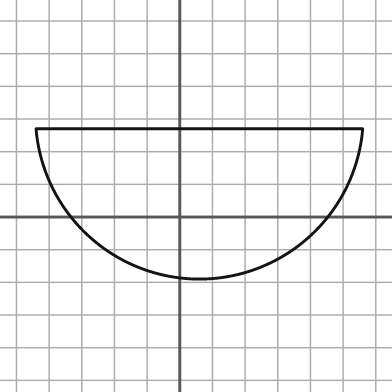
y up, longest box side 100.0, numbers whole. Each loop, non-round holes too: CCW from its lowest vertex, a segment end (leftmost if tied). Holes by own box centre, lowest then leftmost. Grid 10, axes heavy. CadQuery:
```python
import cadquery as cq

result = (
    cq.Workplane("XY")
    .moveTo(-44.0, 27.0)
    .threePointArc((6.0, -19.0), (56.0, 27.0))
    .close()
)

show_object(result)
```